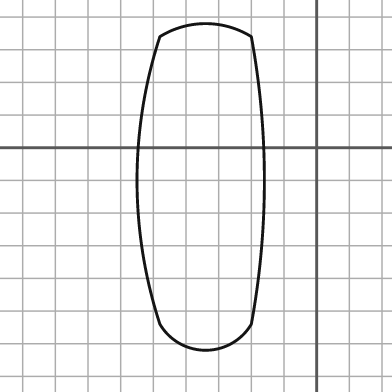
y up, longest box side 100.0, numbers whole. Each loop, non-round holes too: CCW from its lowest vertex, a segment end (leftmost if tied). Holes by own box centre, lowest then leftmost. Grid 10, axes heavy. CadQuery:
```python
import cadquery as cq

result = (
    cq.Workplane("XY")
    .moveTo(-48.0, -54.0)
    .threePointArc((-34.0, -62.0), (-20.0, -54.0))
    .threePointArc((-16.0, -10.0), (-20.0, 34.0))
    .threePointArc((-34.0, 38.0), (-48.0, 34.0))
    .threePointArc((-55.0, -10.0), (-48.0, -54.0))
    .close()
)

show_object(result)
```